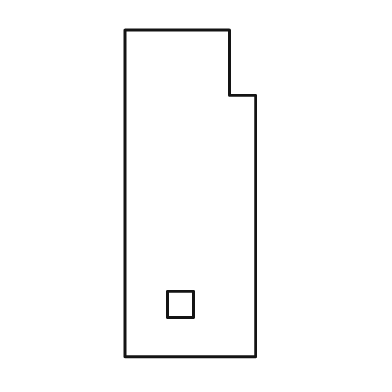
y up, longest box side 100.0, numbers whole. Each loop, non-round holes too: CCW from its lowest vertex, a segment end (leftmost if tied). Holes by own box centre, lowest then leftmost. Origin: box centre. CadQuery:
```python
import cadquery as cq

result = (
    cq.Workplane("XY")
    .moveTo(-20.0, -50.0)
    .lineTo(20.0, -50.0)
    .lineTo(20.0, 30.0)
    .lineTo(12.0, 30.0)
    .lineTo(12.0, 50.0)
    .lineTo(-20.0, 50.0)
    .close()
    .moveTo(-7.0, -38.0)
    .lineTo(1.0, -38.0)
    .lineTo(1.0, -30.0)
    .lineTo(-7.0, -30.0)
    .close()
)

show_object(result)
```